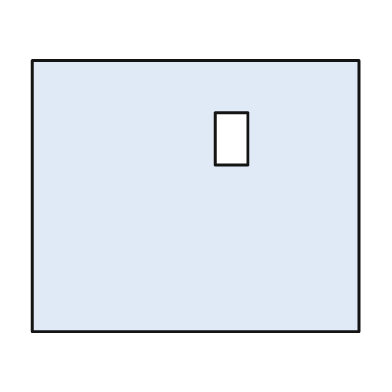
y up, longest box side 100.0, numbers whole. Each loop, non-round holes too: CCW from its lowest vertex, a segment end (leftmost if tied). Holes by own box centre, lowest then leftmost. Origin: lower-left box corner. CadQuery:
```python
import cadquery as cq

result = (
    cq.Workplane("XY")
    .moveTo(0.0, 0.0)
    .lineTo(100.0, 0.0)
    .lineTo(100.0, 83.0)
    .lineTo(0.0, 83.0)
    .close()
    .moveTo(56.0, 51.0)
    .lineTo(66.0, 51.0)
    .lineTo(66.0, 67.0)
    .lineTo(56.0, 67.0)
    .close()
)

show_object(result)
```